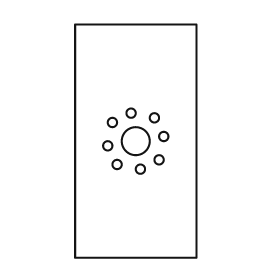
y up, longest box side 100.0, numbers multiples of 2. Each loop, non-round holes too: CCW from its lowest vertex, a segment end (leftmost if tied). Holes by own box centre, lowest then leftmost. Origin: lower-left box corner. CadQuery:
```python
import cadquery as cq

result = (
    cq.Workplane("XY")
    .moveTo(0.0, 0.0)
    .lineTo(52.0, 0.0)
    .lineTo(52.0, 100.0)
    .lineTo(0.0, 100.0)
    .close()
    .moveTo(28.0, 38.0)
    .circle(2.0)
    .moveTo(18.0, 40.0)
    .circle(2.0)
    .moveTo(36.0, 42.0)
    .circle(2.0)
    .moveTo(14.0, 48.0)
    .circle(2.0)
    .moveTo(26.0, 50.0)
    .circle(6.0)
    .moveTo(38.0, 52.0)
    .circle(2.0)
    .moveTo(16.0, 58.0)
    .circle(2.0)
    .moveTo(34.0, 60.0)
    .circle(2.0)
    .moveTo(24.0, 62.0)
    .circle(2.0)
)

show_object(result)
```